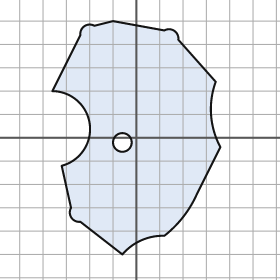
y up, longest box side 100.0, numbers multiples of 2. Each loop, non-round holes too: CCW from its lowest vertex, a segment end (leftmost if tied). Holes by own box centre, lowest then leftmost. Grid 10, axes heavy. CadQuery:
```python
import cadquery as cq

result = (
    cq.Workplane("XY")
    .moveTo(-6.0, -50.0)
    .threePointArc((2.0, -44.0), (12.0, -42.0))
    .threePointArc((20.0, -34.0), (26.0, -24.0))
    .lineTo(36.0, -4.0)
    .threePointArc((32.0, 10.0), (34.0, 24.0))
    .lineTo(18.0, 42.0)
    .threePointArc((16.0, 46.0), (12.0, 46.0))
    .lineTo(-10.0, 50.0)
    .lineTo(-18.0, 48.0)
    .threePointArc((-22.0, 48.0), (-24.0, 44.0))
    .lineTo(-36.0, 20.0)
    .threePointArc((-20.0, 6.0), (-32.0, -12.0))
    .lineTo(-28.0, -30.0)
    .threePointArc((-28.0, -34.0), (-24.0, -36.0))
    .close()
    .moveTo(-6.0, -2.0)
    .circle(4.0)
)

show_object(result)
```